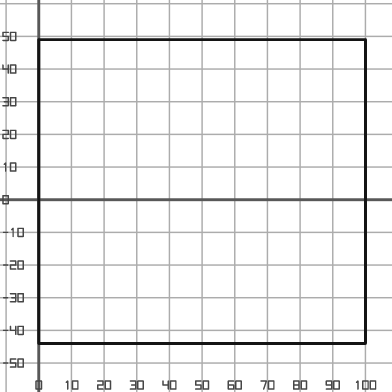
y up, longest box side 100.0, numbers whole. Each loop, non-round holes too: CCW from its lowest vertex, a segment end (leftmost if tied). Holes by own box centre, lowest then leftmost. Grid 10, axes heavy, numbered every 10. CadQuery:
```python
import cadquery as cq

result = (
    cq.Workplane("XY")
    .moveTo(0.0, -44.0)
    .lineTo(100.0, -44.0)
    .lineTo(100.0, 49.0)
    .lineTo(0.0, 49.0)
    .close()
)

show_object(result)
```